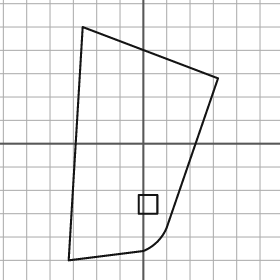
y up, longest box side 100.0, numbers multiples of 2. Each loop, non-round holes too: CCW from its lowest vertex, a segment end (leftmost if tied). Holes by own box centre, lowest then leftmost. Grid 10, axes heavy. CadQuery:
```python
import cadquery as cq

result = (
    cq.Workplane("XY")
    .moveTo(-32.0, -50.0)
    .lineTo(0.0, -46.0)
    .threePointArc((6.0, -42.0), (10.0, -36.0))
    .lineTo(32.0, 28.0)
    .lineTo(-26.0, 50.0)
    .close()
    .moveTo(-2.0, -30.0)
    .lineTo(6.0, -30.0)
    .lineTo(6.0, -22.0)
    .lineTo(-2.0, -22.0)
    .close()
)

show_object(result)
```